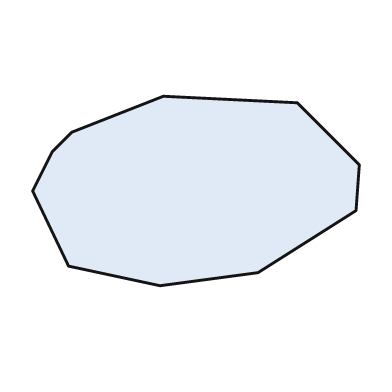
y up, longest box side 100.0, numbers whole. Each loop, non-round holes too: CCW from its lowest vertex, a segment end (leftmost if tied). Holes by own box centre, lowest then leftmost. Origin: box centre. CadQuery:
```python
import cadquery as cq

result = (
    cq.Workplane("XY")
    .moveTo(-11.0, -29.0)
    .lineTo(19.0, -25.0)
    .lineTo(49.0, -6.0)
    .lineTo(50.0, 8.0)
    .lineTo(31.0, 27.0)
    .lineTo(-10.0, 29.0)
    .lineTo(-38.0, 18.0)
    .lineTo(-44.0, 12.0)
    .lineTo(-50.0, 0.0)
    .lineTo(-39.0, -23.0)
    .close()
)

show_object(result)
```